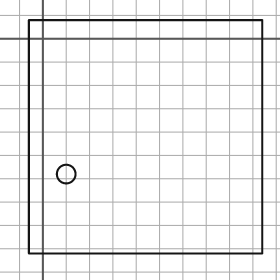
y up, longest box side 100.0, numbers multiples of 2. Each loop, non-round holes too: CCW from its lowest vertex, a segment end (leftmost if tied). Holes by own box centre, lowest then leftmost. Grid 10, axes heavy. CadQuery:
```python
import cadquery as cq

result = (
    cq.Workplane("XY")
    .moveTo(-6.0, -92.0)
    .lineTo(94.0, -92.0)
    .lineTo(94.0, 8.0)
    .lineTo(-6.0, 8.0)
    .close()
    .moveTo(10.0, -58.0)
    .circle(4.0)
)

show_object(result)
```